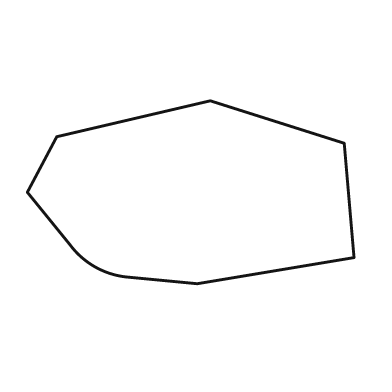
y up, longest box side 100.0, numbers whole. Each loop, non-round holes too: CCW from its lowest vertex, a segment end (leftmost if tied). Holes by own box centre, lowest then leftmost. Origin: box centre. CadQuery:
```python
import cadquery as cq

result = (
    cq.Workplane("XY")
    .moveTo(2.0, -28.0)
    .lineTo(50.0, -20.0)
    .lineTo(47.0, 15.0)
    .lineTo(6.0, 28.0)
    .lineTo(-41.0, 17.0)
    .lineTo(-50.0, 0.0)
    .lineTo(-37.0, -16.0)
    .threePointArc((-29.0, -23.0), (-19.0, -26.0))
    .close()
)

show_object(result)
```